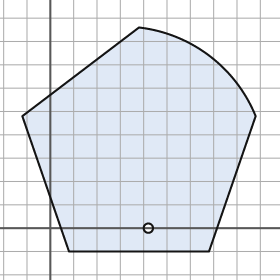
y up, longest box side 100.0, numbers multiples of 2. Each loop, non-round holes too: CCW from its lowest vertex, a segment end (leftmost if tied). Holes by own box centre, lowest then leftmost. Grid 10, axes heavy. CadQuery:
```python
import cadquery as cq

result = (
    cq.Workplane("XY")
    .moveTo(8.0, -10.0)
    .lineTo(68.0, -10.0)
    .lineTo(88.0, 48.0)
    .threePointArc((68.0, 74.0), (38.0, 86.0))
    .lineTo(-12.0, 48.0)
    .close()
    .moveTo(42.0, 0.0)
    .circle(2.0)
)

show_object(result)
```